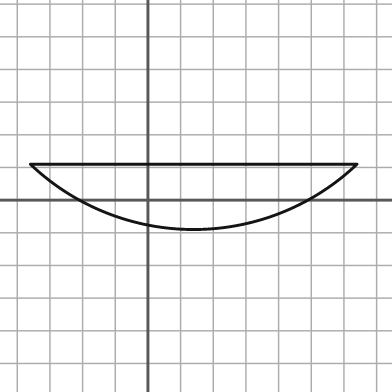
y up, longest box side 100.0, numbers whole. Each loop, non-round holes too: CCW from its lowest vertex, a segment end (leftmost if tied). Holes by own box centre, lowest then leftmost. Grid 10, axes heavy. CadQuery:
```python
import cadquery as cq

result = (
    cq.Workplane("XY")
    .moveTo(-36.0, 11.0)
    .threePointArc((14.0, -9.0), (64.0, 11.0))
    .close()
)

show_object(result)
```